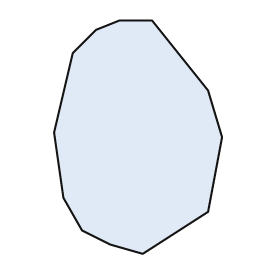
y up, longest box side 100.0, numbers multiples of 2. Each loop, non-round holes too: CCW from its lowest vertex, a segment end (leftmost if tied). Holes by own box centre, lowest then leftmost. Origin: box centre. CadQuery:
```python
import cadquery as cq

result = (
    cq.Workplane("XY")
    .moveTo(2.0, -50.0)
    .lineTo(30.0, -32.0)
    .lineTo(36.0, 0.0)
    .lineTo(30.0, 20.0)
    .lineTo(6.0, 50.0)
    .lineTo(-8.0, 50.0)
    .lineTo(-18.0, 46.0)
    .lineTo(-28.0, 36.0)
    .lineTo(-36.0, 2.0)
    .lineTo(-32.0, -26.0)
    .lineTo(-24.0, -40.0)
    .lineTo(-12.0, -46.0)
    .close()
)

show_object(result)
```